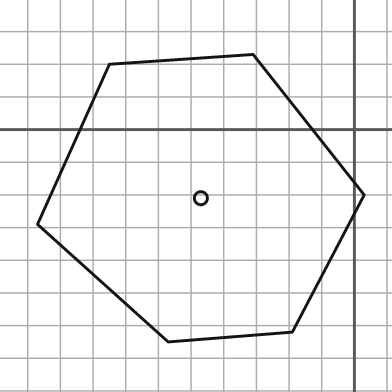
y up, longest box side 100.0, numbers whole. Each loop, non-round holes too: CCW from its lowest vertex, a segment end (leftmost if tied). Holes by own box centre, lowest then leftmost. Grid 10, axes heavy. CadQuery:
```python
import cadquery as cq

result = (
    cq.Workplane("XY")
    .moveTo(-57.0, -65.0)
    .lineTo(-19.0, -62.0)
    .lineTo(3.0, -20.0)
    .lineTo(-31.0, 23.0)
    .lineTo(-75.0, 20.0)
    .lineTo(-97.0, -29.0)
    .close()
    .moveTo(-47.0, -21.0)
    .circle(2.0)
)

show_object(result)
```